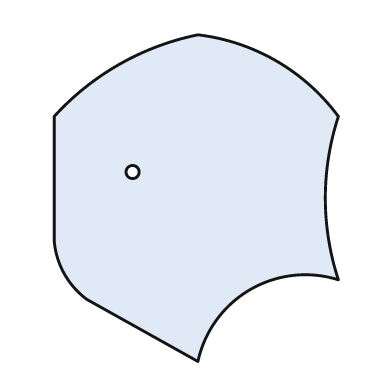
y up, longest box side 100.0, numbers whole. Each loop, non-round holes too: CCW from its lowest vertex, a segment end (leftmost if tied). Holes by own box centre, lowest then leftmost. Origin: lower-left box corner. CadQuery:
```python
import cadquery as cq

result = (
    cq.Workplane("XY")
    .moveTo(44.0, 0.0)
    .threePointArc((60.0, 22.0), (87.0, 25.0))
    .threePointArc((83.0, 50.0), (87.0, 75.0))
    .threePointArc((68.0, 92.0), (44.0, 100.0))
    .threePointArc((20.0, 91.0), (0.0, 75.0))
    .lineTo(0.0, 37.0)
    .threePointArc((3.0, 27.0), (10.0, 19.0))
    .close()
    .moveTo(24.0, 58.0)
    .circle(2.0)
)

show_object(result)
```